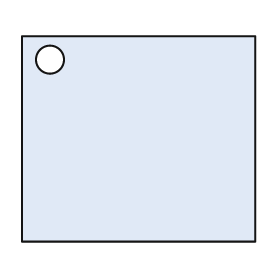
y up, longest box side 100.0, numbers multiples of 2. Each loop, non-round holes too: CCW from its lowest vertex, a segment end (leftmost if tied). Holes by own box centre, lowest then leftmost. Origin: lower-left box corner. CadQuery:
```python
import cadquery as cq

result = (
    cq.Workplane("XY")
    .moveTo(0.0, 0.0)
    .lineTo(100.0, 0.0)
    .lineTo(100.0, 88.0)
    .lineTo(0.0, 88.0)
    .close()
    .moveTo(12.0, 78.0)
    .circle(6.0)
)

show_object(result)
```